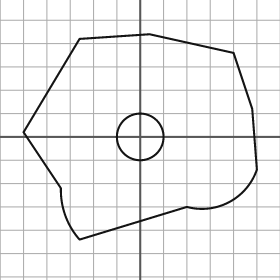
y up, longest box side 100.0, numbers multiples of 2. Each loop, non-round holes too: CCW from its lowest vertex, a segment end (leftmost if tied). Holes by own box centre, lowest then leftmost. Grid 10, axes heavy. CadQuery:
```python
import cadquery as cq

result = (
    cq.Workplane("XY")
    .moveTo(-26.0, -44.0)
    .lineTo(20.0, -30.0)
    .threePointArc((38.0, -28.0), (50.0, -14.0))
    .lineTo(48.0, 12.0)
    .lineTo(40.0, 36.0)
    .lineTo(4.0, 44.0)
    .lineTo(-26.0, 42.0)
    .lineTo(-50.0, 2.0)
    .lineTo(-34.0, -22.0)
    .threePointArc((-32.0, -34.0), (-26.0, -44.0))
    .close()
    .moveTo(0.0, 0.0)
    .circle(10.0)
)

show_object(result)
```